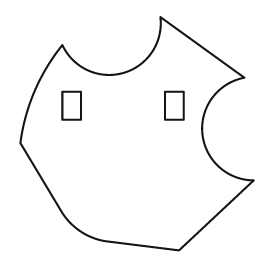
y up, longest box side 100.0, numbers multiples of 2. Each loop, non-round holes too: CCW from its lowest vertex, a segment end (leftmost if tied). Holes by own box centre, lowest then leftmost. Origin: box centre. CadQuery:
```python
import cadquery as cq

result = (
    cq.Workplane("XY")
    .moveTo(18.0, -50.0)
    .lineTo(50.0, -20.0)
    .threePointArc((28.0, 0.0), (46.0, 24.0))
    .lineTo(10.0, 50.0)
    .threePointArc((-6.0, 26.0), (-32.0, 38.0))
    .threePointArc((-44.0, 18.0), (-50.0, -4.0))
    .lineTo(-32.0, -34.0)
    .threePointArc((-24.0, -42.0), (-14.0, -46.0))
    .close()
    .moveTo(-32.0, 6.0)
    .lineTo(-24.0, 6.0)
    .lineTo(-24.0, 18.0)
    .lineTo(-32.0, 18.0)
    .close()
    .moveTo(12.0, 6.0)
    .lineTo(20.0, 6.0)
    .lineTo(20.0, 18.0)
    .lineTo(12.0, 18.0)
    .close()
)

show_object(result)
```